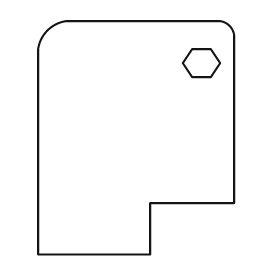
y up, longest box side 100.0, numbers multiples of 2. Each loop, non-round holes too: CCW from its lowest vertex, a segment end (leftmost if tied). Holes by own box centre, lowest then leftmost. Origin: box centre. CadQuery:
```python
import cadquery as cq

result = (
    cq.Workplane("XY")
    .moveTo(-42.0, -50.0)
    .lineTo(6.0, -50.0)
    .lineTo(6.0, -28.0)
    .lineTo(42.0, -28.0)
    .lineTo(42.0, 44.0)
    .threePointArc((40.0, 48.0), (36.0, 50.0))
    .lineTo(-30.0, 50.0)
    .threePointArc((-38.0, 46.0), (-42.0, 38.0))
    .close()
    .moveTo(24.0, 26.0)
    .lineTo(32.0, 26.0)
    .lineTo(36.0, 32.0)
    .lineTo(32.0, 38.0)
    .lineTo(24.0, 38.0)
    .lineTo(20.0, 32.0)
    .close()
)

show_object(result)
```